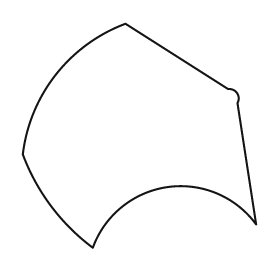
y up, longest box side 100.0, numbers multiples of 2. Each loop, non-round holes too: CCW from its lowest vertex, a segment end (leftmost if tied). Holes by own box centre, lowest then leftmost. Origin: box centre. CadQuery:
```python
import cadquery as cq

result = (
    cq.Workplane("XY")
    .moveTo(-20.0, -48.0)
    .threePointArc((12.0, -22.0), (50.0, -38.0))
    .lineTo(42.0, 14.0)
    .threePointArc((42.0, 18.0), (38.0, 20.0))
    .lineTo(-6.0, 48.0)
    .threePointArc((-36.0, 26.0), (-50.0, -8.0))
    .threePointArc((-38.0, -30.0), (-20.0, -48.0))
    .close()
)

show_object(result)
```